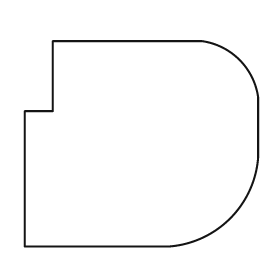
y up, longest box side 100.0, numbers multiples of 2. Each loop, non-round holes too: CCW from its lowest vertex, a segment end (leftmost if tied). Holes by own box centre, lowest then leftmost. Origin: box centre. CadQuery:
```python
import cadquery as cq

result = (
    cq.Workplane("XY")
    .moveTo(-50.0, -44.0)
    .lineTo(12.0, -44.0)
    .threePointArc((38.0, -32.0), (50.0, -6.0))
    .lineTo(50.0, 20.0)
    .threePointArc((42.0, 36.0), (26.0, 44.0))
    .lineTo(-38.0, 44.0)
    .lineTo(-38.0, 14.0)
    .lineTo(-50.0, 14.0)
    .close()
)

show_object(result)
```